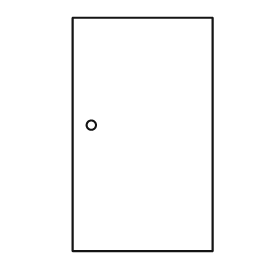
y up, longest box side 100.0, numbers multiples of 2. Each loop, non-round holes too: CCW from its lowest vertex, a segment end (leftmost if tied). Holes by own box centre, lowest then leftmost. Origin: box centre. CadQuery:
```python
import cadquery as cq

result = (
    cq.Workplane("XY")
    .moveTo(-30.0, -50.0)
    .lineTo(30.0, -50.0)
    .lineTo(30.0, 50.0)
    .lineTo(-30.0, 50.0)
    .close()
    .moveTo(-22.0, 4.0)
    .circle(2.0)
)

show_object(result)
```